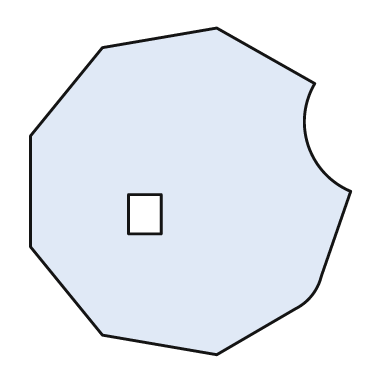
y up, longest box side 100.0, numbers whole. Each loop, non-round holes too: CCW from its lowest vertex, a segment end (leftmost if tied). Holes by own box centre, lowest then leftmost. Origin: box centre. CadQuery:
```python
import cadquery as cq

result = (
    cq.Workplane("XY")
    .moveTo(8.0, -50.0)
    .lineTo(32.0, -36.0)
    .threePointArc((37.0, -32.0), (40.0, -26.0))
    .lineTo(49.0, 0.0)
    .threePointArc((36.0, 14.0), (38.0, 33.0))
    .lineTo(8.0, 50.0)
    .lineTo(-27.0, 44.0)
    .lineTo(-49.0, 17.0)
    .lineTo(-49.0, -17.0)
    .lineTo(-27.0, -44.0)
    .close()
    .moveTo(-19.0, -13.0)
    .lineTo(-9.0, -13.0)
    .lineTo(-9.0, -1.0)
    .lineTo(-19.0, -1.0)
    .close()
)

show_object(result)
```